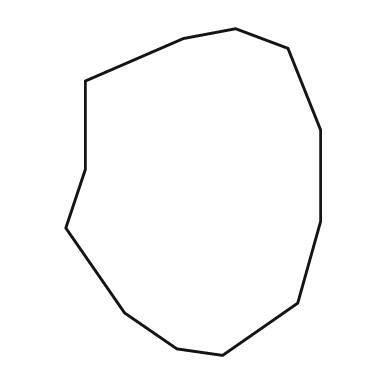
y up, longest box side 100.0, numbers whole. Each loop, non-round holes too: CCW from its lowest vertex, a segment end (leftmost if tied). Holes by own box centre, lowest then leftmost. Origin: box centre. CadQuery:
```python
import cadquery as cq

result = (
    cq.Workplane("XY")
    .moveTo(9.0, -50.0)
    .lineTo(32.0, -34.0)
    .lineTo(39.0, -9.0)
    .lineTo(39.0, 19.0)
    .lineTo(29.0, 44.0)
    .lineTo(13.0, 50.0)
    .lineTo(-3.0, 47.0)
    .lineTo(-33.0, 34.0)
    .lineTo(-33.0, 7.0)
    .lineTo(-39.0, -11.0)
    .lineTo(-21.0, -37.0)
    .lineTo(-5.0, -48.0)
    .close()
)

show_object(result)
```